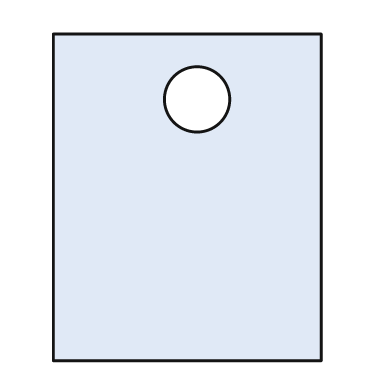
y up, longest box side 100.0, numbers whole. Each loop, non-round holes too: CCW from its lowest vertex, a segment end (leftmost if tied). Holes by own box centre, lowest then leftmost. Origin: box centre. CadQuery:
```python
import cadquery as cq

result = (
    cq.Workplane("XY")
    .moveTo(-41.0, -50.0)
    .lineTo(41.0, -50.0)
    .lineTo(41.0, 50.0)
    .lineTo(-41.0, 50.0)
    .close()
    .moveTo(3.0, 30.0)
    .circle(10.0)
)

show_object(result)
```